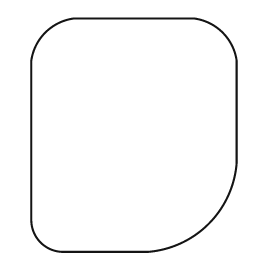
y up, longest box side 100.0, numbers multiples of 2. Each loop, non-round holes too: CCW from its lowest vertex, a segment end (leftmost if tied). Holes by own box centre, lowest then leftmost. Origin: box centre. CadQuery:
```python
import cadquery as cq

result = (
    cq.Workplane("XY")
    .moveTo(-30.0, -50.0)
    .lineTo(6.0, -50.0)
    .threePointArc((32.0, -38.0), (44.0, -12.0))
    .lineTo(44.0, 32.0)
    .threePointArc((38.0, 44.0), (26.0, 50.0))
    .lineTo(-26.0, 50.0)
    .threePointArc((-38.0, 44.0), (-44.0, 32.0))
    .lineTo(-44.0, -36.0)
    .threePointArc((-40.0, -46.0), (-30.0, -50.0))
    .close()
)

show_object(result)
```